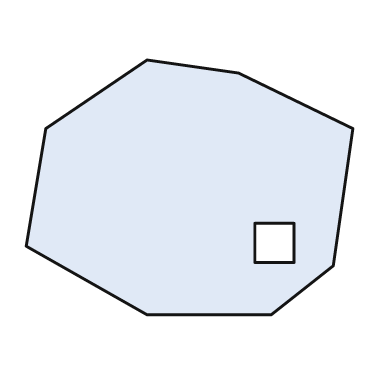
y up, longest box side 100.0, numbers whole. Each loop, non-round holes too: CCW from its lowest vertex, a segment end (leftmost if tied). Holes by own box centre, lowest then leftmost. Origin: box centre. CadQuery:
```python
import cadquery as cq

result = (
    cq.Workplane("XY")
    .moveTo(-13.0, -39.0)
    .lineTo(25.0, -39.0)
    .lineTo(44.0, -24.0)
    .lineTo(50.0, 18.0)
    .lineTo(15.0, 35.0)
    .lineTo(-13.0, 39.0)
    .lineTo(-44.0, 18.0)
    .lineTo(-50.0, -18.0)
    .close()
    .moveTo(20.0, -23.0)
    .lineTo(32.0, -23.0)
    .lineTo(32.0, -11.0)
    .lineTo(20.0, -11.0)
    .close()
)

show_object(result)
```